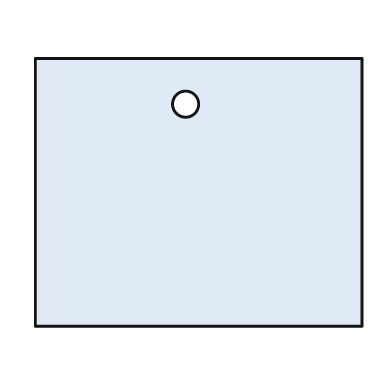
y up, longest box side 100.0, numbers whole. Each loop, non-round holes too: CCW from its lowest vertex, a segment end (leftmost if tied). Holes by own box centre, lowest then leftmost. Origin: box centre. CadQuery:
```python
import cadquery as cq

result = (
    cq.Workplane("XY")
    .moveTo(-50.0, -41.0)
    .lineTo(50.0, -41.0)
    .lineTo(50.0, 41.0)
    .lineTo(-50.0, 41.0)
    .close()
    .moveTo(-4.0, 27.0)
    .circle(4.0)
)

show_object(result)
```